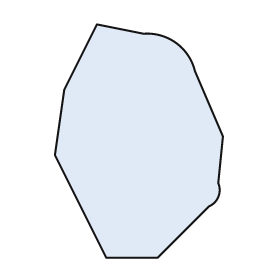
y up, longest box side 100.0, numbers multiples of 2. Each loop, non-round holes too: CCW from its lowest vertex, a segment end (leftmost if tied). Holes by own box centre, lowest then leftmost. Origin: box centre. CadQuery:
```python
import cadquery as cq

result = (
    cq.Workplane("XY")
    .moveTo(-14.0, -50.0)
    .lineTo(8.0, -50.0)
    .lineTo(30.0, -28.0)
    .threePointArc((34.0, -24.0), (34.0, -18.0))
    .lineTo(36.0, 2.0)
    .lineTo(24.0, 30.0)
    .threePointArc((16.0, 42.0), (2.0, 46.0))
    .lineTo(-18.0, 50.0)
    .lineTo(-32.0, 22.0)
    .lineTo(-36.0, -6.0)
    .close()
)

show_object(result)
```